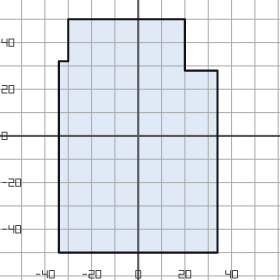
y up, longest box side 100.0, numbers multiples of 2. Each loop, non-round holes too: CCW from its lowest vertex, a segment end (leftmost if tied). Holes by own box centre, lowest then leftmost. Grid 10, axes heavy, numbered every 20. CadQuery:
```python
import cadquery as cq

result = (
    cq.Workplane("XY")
    .moveTo(-34.0, -50.0)
    .lineTo(34.0, -50.0)
    .lineTo(34.0, 28.0)
    .lineTo(20.0, 28.0)
    .lineTo(20.0, 50.0)
    .lineTo(-30.0, 50.0)
    .lineTo(-30.0, 32.0)
    .lineTo(-34.0, 32.0)
    .close()
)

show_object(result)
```